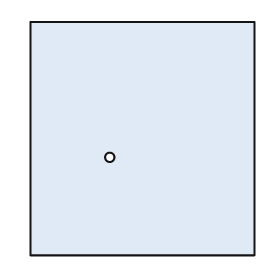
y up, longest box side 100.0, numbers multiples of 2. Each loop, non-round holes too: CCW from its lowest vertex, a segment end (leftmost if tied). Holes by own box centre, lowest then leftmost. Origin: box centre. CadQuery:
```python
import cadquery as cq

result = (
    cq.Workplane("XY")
    .moveTo(-48.0, -50.0)
    .lineTo(48.0, -50.0)
    .lineTo(48.0, 50.0)
    .lineTo(-48.0, 50.0)
    .close()
    .moveTo(-14.0, -8.0)
    .circle(2.0)
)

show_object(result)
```